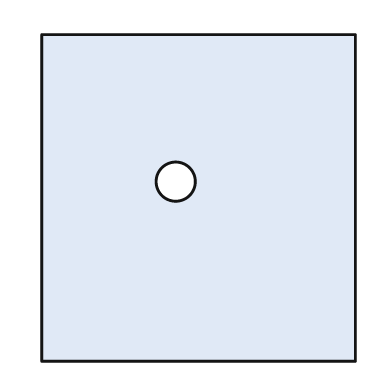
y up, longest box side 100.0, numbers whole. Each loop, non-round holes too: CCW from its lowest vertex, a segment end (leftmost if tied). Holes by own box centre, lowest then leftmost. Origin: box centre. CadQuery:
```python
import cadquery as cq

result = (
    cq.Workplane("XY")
    .moveTo(-48.0, -50.0)
    .lineTo(48.0, -50.0)
    .lineTo(48.0, 50.0)
    .lineTo(-48.0, 50.0)
    .close()
    .moveTo(-7.0, 5.0)
    .circle(6.0)
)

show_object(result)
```